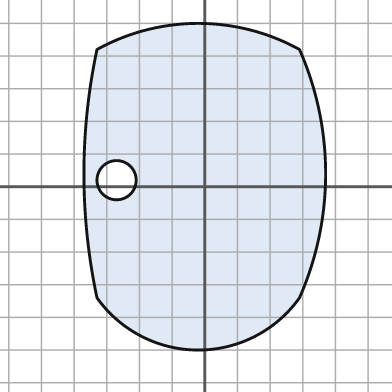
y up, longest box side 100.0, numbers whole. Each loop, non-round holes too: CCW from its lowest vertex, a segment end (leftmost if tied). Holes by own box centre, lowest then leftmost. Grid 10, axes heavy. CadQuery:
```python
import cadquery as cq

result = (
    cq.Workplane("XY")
    .moveTo(-33.0, -34.0)
    .threePointArc((-2.0, -50.0), (29.0, -34.0))
    .threePointArc((37.0, 4.0), (29.0, 42.0))
    .threePointArc((-2.0, 50.0), (-33.0, 42.0))
    .threePointArc((-37.0, 4.0), (-33.0, -34.0))
    .close()
    .moveTo(-27.0, 2.0)
    .circle(6.0)
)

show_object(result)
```